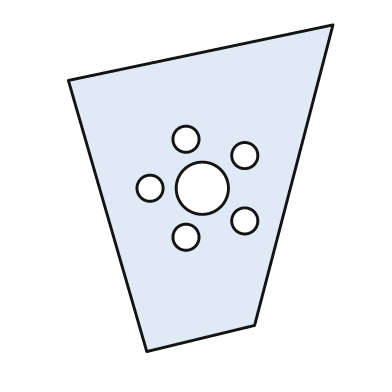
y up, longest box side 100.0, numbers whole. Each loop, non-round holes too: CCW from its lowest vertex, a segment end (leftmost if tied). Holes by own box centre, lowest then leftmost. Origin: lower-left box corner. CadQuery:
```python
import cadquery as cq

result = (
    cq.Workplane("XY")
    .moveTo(24.0, 0.0)
    .lineTo(57.0, 8.0)
    .lineTo(81.0, 100.0)
    .lineTo(0.0, 83.0)
    .close()
    .moveTo(36.0, 35.0)
    .circle(4.0)
    .moveTo(54.0, 40.0)
    .circle(4.0)
    .moveTo(25.0, 50.0)
    .circle(4.0)
    .moveTo(41.0, 50.0)
    .circle(8.0)
    .moveTo(54.0, 60.0)
    .circle(4.0)
    .moveTo(36.0, 65.0)
    .circle(4.0)
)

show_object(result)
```